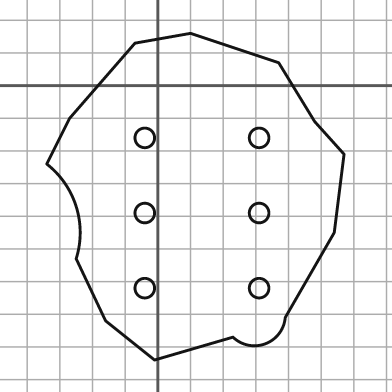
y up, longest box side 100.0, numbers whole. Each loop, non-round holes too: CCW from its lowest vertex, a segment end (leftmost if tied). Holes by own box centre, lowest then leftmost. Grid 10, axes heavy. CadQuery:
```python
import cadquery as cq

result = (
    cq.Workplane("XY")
    .moveTo(-1.0, -84.0)
    .lineTo(23.0, -77.0)
    .threePointArc((33.0, -79.0), (39.0, -71.0))
    .lineTo(54.0, -45.0)
    .lineTo(57.0, -21.0)
    .lineTo(48.0, -11.0)
    .lineTo(37.0, 7.0)
    .lineTo(10.0, 16.0)
    .lineTo(-7.0, 13.0)
    .lineTo(-27.0, -10.0)
    .lineTo(-34.0, -24.0)
    .threePointArc((-25.0, -37.0), (-25.0, -53.0))
    .lineTo(-16.0, -72.0)
    .close()
    .moveTo(-4.0, -62.0)
    .circle(3.0)
    .moveTo(31.0, -62.0)
    .circle(3.0)
    .moveTo(-4.0, -39.0)
    .circle(3.0)
    .moveTo(31.0, -39.0)
    .circle(3.0)
    .moveTo(-4.0, -16.0)
    .circle(3.0)
    .moveTo(31.0, -16.0)
    .circle(3.0)
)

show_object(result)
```